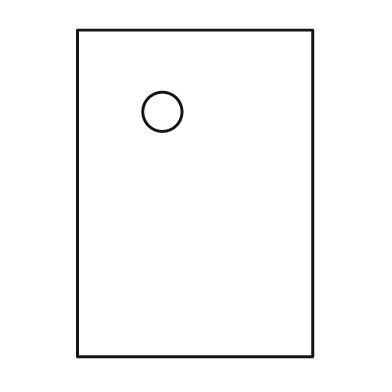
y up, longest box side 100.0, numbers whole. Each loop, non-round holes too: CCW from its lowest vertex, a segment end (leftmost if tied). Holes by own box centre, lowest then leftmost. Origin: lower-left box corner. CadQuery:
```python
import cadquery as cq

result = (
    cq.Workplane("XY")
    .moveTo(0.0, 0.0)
    .lineTo(72.0, 0.0)
    .lineTo(72.0, 100.0)
    .lineTo(0.0, 100.0)
    .close()
    .moveTo(26.0, 75.0)
    .circle(6.0)
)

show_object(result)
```